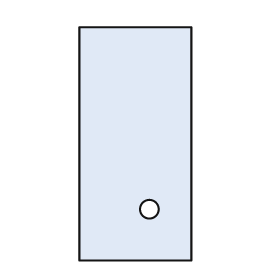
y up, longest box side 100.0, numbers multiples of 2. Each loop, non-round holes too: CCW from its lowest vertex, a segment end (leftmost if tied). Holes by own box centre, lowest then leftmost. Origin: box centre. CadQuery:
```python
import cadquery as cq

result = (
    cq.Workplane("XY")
    .moveTo(-24.0, -50.0)
    .lineTo(24.0, -50.0)
    .lineTo(24.0, 50.0)
    .lineTo(-24.0, 50.0)
    .close()
    .moveTo(6.0, -28.0)
    .circle(4.0)
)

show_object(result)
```